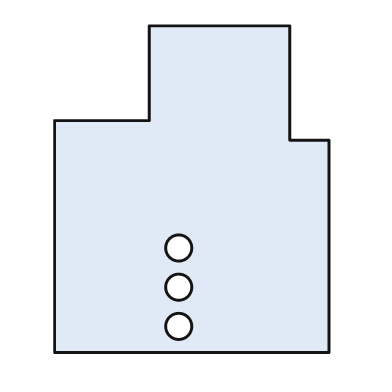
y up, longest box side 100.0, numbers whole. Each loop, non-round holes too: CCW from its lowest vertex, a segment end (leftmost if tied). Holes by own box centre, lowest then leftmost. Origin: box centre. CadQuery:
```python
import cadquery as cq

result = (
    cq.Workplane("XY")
    .moveTo(-42.0, -50.0)
    .lineTo(42.0, -50.0)
    .lineTo(42.0, 15.0)
    .lineTo(30.0, 15.0)
    .lineTo(30.0, 50.0)
    .lineTo(-13.0, 50.0)
    .lineTo(-13.0, 21.0)
    .lineTo(-42.0, 21.0)
    .close()
    .moveTo(-4.0, -42.0)
    .circle(4.0)
    .moveTo(-4.0, -30.0)
    .circle(4.0)
    .moveTo(-4.0, -18.0)
    .circle(4.0)
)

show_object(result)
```